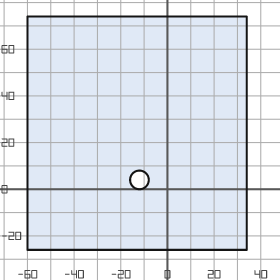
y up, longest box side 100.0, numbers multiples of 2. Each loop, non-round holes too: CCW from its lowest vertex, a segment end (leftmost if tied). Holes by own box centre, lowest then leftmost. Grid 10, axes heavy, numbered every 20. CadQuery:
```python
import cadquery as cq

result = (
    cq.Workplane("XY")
    .moveTo(-60.0, -26.0)
    .lineTo(34.0, -26.0)
    .lineTo(34.0, 74.0)
    .lineTo(-60.0, 74.0)
    .close()
    .moveTo(-12.0, 4.0)
    .circle(4.0)
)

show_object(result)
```